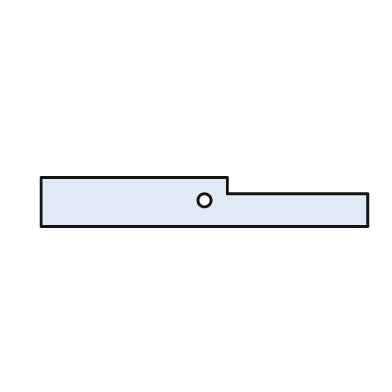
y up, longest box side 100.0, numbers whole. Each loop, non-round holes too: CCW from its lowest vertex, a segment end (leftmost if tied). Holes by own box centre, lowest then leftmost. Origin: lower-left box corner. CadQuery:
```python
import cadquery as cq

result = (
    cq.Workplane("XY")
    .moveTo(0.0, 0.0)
    .lineTo(100.0, 0.0)
    .lineTo(100.0, 10.0)
    .lineTo(57.0, 10.0)
    .lineTo(57.0, 15.0)
    .lineTo(0.0, 15.0)
    .close()
    .moveTo(50.0, 8.0)
    .circle(2.0)
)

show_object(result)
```